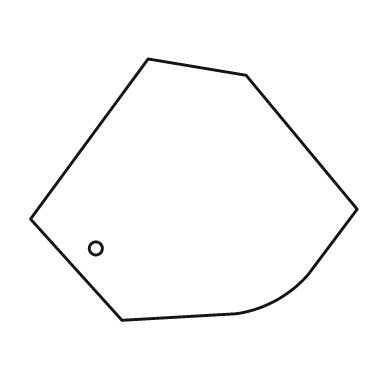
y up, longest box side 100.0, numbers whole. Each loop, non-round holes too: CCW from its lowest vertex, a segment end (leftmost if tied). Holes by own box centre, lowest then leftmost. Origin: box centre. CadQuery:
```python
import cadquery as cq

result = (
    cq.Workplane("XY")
    .moveTo(-22.0, -40.0)
    .lineTo(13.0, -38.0)
    .threePointArc((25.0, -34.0), (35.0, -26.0))
    .lineTo(50.0, -6.0)
    .lineTo(16.0, 35.0)
    .lineTo(-14.0, 40.0)
    .lineTo(-50.0, -9.0)
    .close()
    .moveTo(-30.0, -18.0)
    .circle(2.0)
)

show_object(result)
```